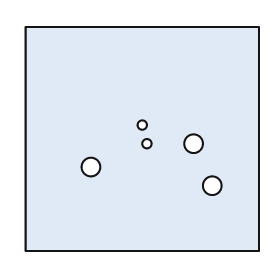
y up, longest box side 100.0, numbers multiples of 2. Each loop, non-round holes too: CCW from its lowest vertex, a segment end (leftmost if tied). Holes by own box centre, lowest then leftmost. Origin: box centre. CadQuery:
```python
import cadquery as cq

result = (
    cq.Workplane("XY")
    .moveTo(-50.0, -48.0)
    .lineTo(50.0, -48.0)
    .lineTo(50.0, 48.0)
    .lineTo(-50.0, 48.0)
    .close()
    .moveTo(30.0, -20.0)
    .circle(4.0)
    .moveTo(-22.0, -12.0)
    .circle(4.0)
    .moveTo(2.0, -2.0)
    .circle(2.0)
    .moveTo(22.0, -2.0)
    .circle(4.0)
    .moveTo(0.0, 6.0)
    .circle(2.0)
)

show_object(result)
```